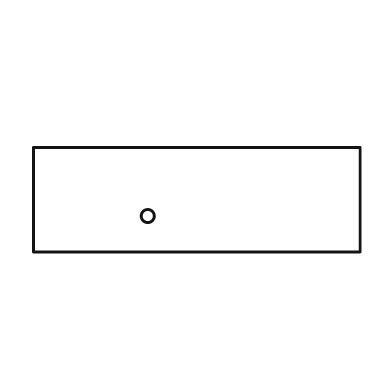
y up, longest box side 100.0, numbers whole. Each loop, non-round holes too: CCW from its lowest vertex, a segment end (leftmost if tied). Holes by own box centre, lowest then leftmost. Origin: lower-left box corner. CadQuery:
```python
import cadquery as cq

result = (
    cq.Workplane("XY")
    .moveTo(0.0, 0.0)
    .lineTo(100.0, 0.0)
    .lineTo(100.0, 32.0)
    .lineTo(0.0, 32.0)
    .close()
    .moveTo(35.0, 11.0)
    .circle(2.0)
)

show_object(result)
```